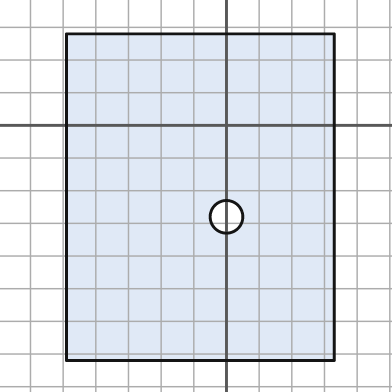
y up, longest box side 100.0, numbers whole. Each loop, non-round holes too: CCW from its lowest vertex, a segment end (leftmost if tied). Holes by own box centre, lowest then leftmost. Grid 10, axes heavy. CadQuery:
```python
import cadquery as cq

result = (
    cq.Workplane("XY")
    .moveTo(-49.0, -72.0)
    .lineTo(33.0, -72.0)
    .lineTo(33.0, 28.0)
    .lineTo(-49.0, 28.0)
    .close()
    .moveTo(0.0, -28.0)
    .circle(5.0)
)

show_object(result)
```